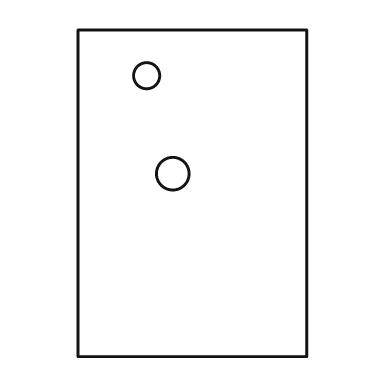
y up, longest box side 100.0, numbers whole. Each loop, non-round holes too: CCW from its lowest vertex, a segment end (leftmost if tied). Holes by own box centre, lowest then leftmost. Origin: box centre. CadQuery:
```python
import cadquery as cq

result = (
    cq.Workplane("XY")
    .moveTo(-35.0, -50.0)
    .lineTo(35.0, -50.0)
    .lineTo(35.0, 50.0)
    .lineTo(-35.0, 50.0)
    .close()
    .moveTo(-6.0, 6.0)
    .circle(5.0)
    .moveTo(-14.0, 36.0)
    .circle(4.0)
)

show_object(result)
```